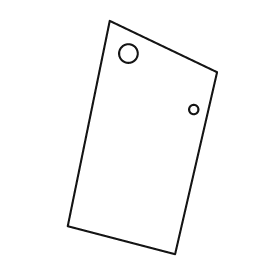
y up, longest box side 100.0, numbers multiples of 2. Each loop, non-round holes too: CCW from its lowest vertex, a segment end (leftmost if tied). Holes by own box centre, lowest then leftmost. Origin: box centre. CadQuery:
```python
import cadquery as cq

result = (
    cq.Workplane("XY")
    .moveTo(14.0, -50.0)
    .lineTo(32.0, 28.0)
    .lineTo(-14.0, 50.0)
    .lineTo(-32.0, -38.0)
    .close()
    .moveTo(22.0, 12.0)
    .circle(2.0)
    .moveTo(-6.0, 36.0)
    .circle(4.0)
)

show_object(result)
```